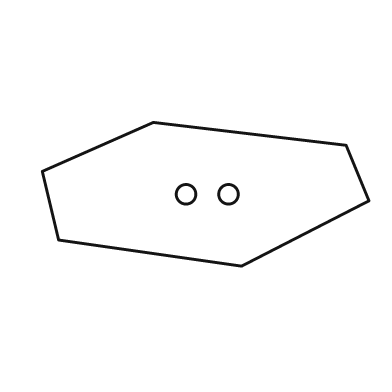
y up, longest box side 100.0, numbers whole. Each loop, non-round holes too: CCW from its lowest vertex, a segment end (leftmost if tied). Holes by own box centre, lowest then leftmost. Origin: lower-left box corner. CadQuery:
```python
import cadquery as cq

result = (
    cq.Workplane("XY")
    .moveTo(61.0, 0.0)
    .lineTo(100.0, 20.0)
    .lineTo(93.0, 37.0)
    .lineTo(34.0, 44.0)
    .lineTo(0.0, 29.0)
    .lineTo(5.0, 8.0)
    .close()
    .moveTo(44.0, 22.0)
    .circle(3.0)
    .moveTo(57.0, 22.0)
    .circle(3.0)
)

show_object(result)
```